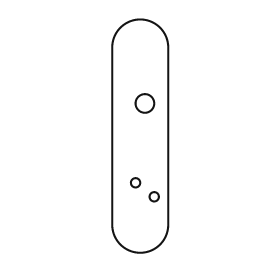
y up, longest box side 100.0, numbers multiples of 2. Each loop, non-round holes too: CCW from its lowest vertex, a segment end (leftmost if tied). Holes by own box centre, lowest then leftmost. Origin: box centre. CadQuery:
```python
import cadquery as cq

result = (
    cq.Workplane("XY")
    .moveTo(-12.0, -38.0)
    .threePointArc((0.0, -50.0), (12.0, -38.0))
    .lineTo(12.0, 38.0)
    .threePointArc((0.0, 50.0), (-12.0, 38.0))
    .close()
    .moveTo(6.0, -26.0)
    .circle(2.0)
    .moveTo(-2.0, -20.0)
    .circle(2.0)
    .moveTo(2.0, 14.0)
    .circle(4.0)
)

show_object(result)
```